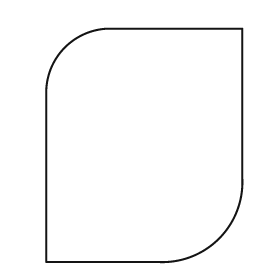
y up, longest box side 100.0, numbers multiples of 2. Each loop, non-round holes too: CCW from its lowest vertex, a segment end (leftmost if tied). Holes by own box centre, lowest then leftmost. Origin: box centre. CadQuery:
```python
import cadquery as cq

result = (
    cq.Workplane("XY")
    .moveTo(-42.0, -50.0)
    .lineTo(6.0, -50.0)
    .threePointArc((32.0, -40.0), (42.0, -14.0))
    .lineTo(42.0, 50.0)
    .lineTo(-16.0, 50.0)
    .threePointArc((-34.0, 42.0), (-42.0, 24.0))
    .close()
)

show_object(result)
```